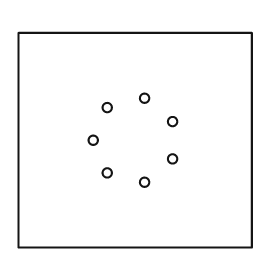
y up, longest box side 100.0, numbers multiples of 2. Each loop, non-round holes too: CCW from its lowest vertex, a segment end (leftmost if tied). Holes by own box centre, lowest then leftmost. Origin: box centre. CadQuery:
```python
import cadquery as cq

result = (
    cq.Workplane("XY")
    .moveTo(-50.0, -46.0)
    .lineTo(50.0, -46.0)
    .lineTo(50.0, 46.0)
    .lineTo(-50.0, 46.0)
    .close()
    .moveTo(4.0, -18.0)
    .circle(2.0)
    .moveTo(-12.0, -14.0)
    .circle(2.0)
    .moveTo(16.0, -8.0)
    .circle(2.0)
    .moveTo(-18.0, 0.0)
    .circle(2.0)
    .moveTo(16.0, 8.0)
    .circle(2.0)
    .moveTo(-12.0, 14.0)
    .circle(2.0)
    .moveTo(4.0, 18.0)
    .circle(2.0)
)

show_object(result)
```